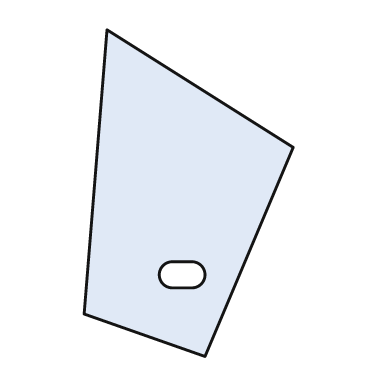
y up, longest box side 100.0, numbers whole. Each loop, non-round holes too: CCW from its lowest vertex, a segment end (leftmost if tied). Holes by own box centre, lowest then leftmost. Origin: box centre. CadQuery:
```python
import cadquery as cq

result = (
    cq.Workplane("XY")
    .moveTo(5.0, -50.0)
    .lineTo(32.0, 14.0)
    .lineTo(-25.0, 50.0)
    .lineTo(-32.0, -37.0)
    .close()
    .moveTo(-5.0, -29.0)
    .lineTo(1.0, -29.0)
    .threePointArc((5.0, -25.0), (1.0, -21.0))
    .lineTo(-5.0, -21.0)
    .threePointArc((-9.0, -25.0), (-5.0, -29.0))
    .close()
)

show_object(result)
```